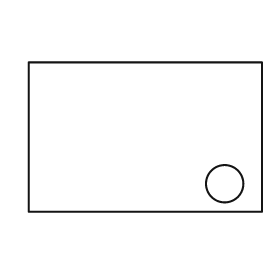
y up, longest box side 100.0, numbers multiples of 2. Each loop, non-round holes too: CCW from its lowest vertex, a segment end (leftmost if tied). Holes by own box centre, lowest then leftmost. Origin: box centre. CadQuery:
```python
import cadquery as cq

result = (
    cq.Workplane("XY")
    .moveTo(-50.0, -32.0)
    .lineTo(50.0, -32.0)
    .lineTo(50.0, 32.0)
    .lineTo(-50.0, 32.0)
    .close()
    .moveTo(34.0, -20.0)
    .circle(8.0)
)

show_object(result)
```